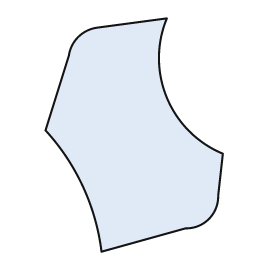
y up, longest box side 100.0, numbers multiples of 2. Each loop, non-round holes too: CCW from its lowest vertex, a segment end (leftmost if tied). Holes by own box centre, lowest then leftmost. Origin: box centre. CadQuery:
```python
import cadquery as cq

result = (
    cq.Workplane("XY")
    .moveTo(-14.0, -50.0)
    .lineTo(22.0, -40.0)
    .threePointArc((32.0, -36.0), (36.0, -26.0))
    .lineTo(38.0, -8.0)
    .threePointArc((14.0, 16.0), (14.0, 50.0))
    .lineTo(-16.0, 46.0)
    .threePointArc((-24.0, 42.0), (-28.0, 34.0))
    .lineTo(-38.0, 2.0)
    .threePointArc((-22.0, -22.0), (-14.0, -50.0))
    .close()
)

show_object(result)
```